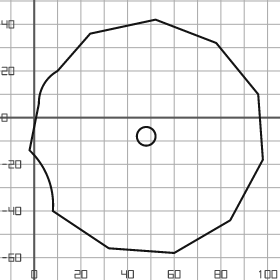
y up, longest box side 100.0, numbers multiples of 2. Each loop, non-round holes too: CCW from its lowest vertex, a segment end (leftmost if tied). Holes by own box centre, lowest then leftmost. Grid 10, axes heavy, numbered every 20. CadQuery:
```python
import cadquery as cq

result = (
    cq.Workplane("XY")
    .moveTo(60.0, -58.0)
    .lineTo(84.0, -44.0)
    .lineTo(98.0, -18.0)
    .lineTo(96.0, 10.0)
    .lineTo(78.0, 32.0)
    .lineTo(52.0, 42.0)
    .lineTo(24.0, 36.0)
    .lineTo(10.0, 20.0)
    .threePointArc((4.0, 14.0), (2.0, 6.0))
    .lineTo(-2.0, -14.0)
    .threePointArc((6.0, -26.0), (8.0, -40.0))
    .lineTo(32.0, -56.0)
    .close()
    .moveTo(48.0, -8.0)
    .circle(4.0)
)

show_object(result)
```